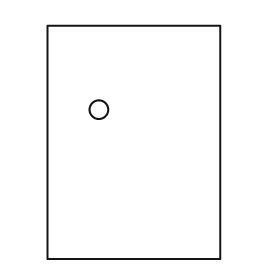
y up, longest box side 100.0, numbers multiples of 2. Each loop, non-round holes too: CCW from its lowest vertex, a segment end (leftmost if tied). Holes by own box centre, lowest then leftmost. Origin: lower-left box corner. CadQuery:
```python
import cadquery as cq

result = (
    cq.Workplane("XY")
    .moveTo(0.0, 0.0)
    .lineTo(74.0, 0.0)
    .lineTo(74.0, 100.0)
    .lineTo(0.0, 100.0)
    .close()
    .moveTo(22.0, 64.0)
    .circle(4.0)
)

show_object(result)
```